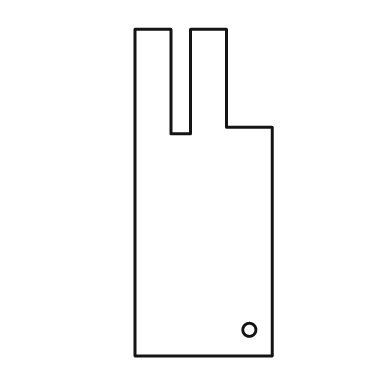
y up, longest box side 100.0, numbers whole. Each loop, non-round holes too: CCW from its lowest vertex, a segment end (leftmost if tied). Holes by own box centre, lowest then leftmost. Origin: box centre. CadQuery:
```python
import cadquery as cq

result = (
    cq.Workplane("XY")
    .moveTo(-21.0, -50.0)
    .lineTo(21.0, -50.0)
    .lineTo(21.0, 20.0)
    .lineTo(7.0, 20.0)
    .lineTo(7.0, 50.0)
    .lineTo(-4.0, 50.0)
    .lineTo(-4.0, 18.0)
    .lineTo(-10.0, 18.0)
    .lineTo(-10.0, 50.0)
    .lineTo(-21.0, 50.0)
    .close()
    .moveTo(14.0, -42.0)
    .circle(2.0)
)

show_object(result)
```